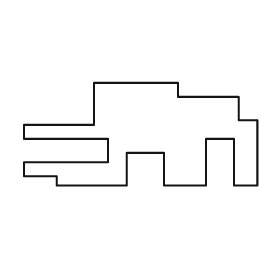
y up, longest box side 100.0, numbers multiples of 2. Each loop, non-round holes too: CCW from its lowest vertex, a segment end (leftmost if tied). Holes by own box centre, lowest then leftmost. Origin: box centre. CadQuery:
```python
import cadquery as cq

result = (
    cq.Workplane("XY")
    .moveTo(-36.0, -22.0)
    .lineTo(-6.0, -22.0)
    .lineTo(-6.0, -8.0)
    .lineTo(10.0, -8.0)
    .lineTo(10.0, -22.0)
    .lineTo(28.0, -22.0)
    .lineTo(28.0, -2.0)
    .lineTo(40.0, -2.0)
    .lineTo(40.0, -22.0)
    .lineTo(50.0, -22.0)
    .lineTo(50.0, 6.0)
    .lineTo(42.0, 6.0)
    .lineTo(42.0, 16.0)
    .lineTo(16.0, 16.0)
    .lineTo(16.0, 22.0)
    .lineTo(-20.0, 22.0)
    .lineTo(-20.0, 4.0)
    .lineTo(-50.0, 4.0)
    .lineTo(-50.0, -2.0)
    .lineTo(-14.0, -2.0)
    .lineTo(-14.0, -12.0)
    .lineTo(-50.0, -12.0)
    .lineTo(-50.0, -18.0)
    .lineTo(-36.0, -18.0)
    .close()
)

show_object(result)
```